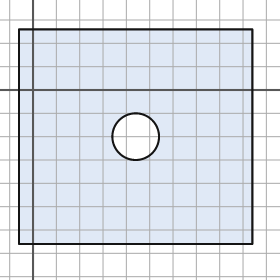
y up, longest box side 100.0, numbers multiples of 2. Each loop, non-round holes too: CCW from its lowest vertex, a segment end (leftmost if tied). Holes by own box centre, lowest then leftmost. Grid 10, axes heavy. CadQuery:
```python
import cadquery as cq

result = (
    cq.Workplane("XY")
    .moveTo(-6.0, -66.0)
    .lineTo(94.0, -66.0)
    .lineTo(94.0, 26.0)
    .lineTo(-6.0, 26.0)
    .close()
    .moveTo(44.0, -20.0)
    .circle(10.0)
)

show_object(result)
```